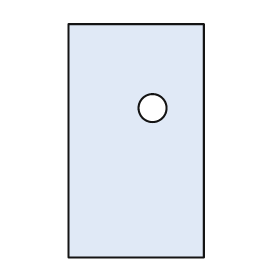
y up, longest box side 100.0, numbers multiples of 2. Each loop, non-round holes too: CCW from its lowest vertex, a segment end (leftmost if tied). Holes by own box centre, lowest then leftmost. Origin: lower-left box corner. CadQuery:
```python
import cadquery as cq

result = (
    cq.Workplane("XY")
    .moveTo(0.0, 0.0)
    .lineTo(58.0, 0.0)
    .lineTo(58.0, 100.0)
    .lineTo(0.0, 100.0)
    .close()
    .moveTo(36.0, 64.0)
    .circle(6.0)
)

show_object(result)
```